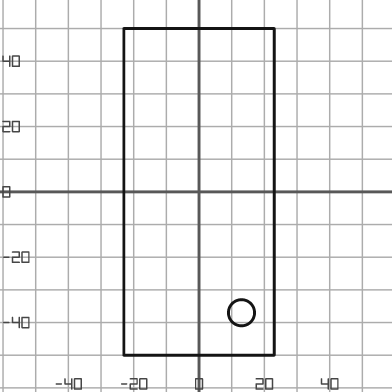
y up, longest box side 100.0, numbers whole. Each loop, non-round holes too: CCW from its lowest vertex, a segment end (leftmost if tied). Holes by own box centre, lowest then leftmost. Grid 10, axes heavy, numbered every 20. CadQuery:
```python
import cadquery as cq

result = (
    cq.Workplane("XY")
    .moveTo(-23.0, -50.0)
    .lineTo(23.0, -50.0)
    .lineTo(23.0, 50.0)
    .lineTo(-23.0, 50.0)
    .close()
    .moveTo(13.0, -37.0)
    .circle(4.0)
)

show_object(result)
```